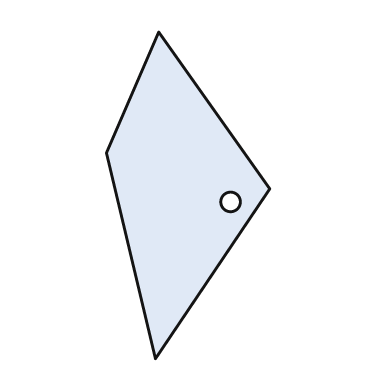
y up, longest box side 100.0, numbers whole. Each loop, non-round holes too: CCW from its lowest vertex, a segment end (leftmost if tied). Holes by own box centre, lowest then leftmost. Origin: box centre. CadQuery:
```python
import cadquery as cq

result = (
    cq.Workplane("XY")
    .moveTo(-10.0, -50.0)
    .lineTo(25.0, 2.0)
    .lineTo(-9.0, 50.0)
    .lineTo(-25.0, 13.0)
    .close()
    .moveTo(13.0, -2.0)
    .circle(3.0)
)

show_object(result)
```